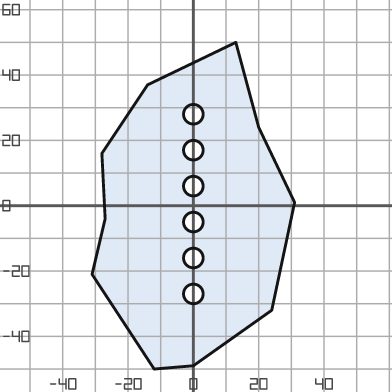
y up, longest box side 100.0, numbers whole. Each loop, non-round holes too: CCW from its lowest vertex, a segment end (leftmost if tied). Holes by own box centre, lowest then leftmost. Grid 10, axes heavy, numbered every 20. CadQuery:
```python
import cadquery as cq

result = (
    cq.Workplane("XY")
    .moveTo(-12.0, -50.0)
    .lineTo(0.0, -49.0)
    .lineTo(24.0, -32.0)
    .lineTo(31.0, 1.0)
    .lineTo(20.0, 24.0)
    .lineTo(13.0, 50.0)
    .lineTo(-14.0, 37.0)
    .lineTo(-28.0, 16.0)
    .lineTo(-27.0, -4.0)
    .lineTo(-31.0, -21.0)
    .close()
    .moveTo(0.0, -27.0)
    .circle(3.0)
    .moveTo(0.0, -16.0)
    .circle(3.0)
    .moveTo(0.0, -5.0)
    .circle(3.0)
    .moveTo(0.0, 6.0)
    .circle(3.0)
    .moveTo(0.0, 17.0)
    .circle(3.0)
    .moveTo(0.0, 28.0)
    .circle(3.0)
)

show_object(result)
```